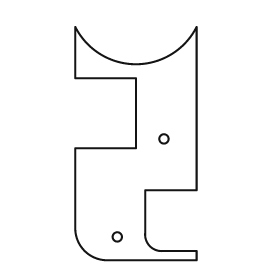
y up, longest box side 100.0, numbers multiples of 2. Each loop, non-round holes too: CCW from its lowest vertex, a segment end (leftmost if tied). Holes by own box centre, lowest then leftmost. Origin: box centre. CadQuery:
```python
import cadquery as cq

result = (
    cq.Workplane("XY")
    .moveTo(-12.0, -50.0)
    .lineTo(26.0, -50.0)
    .lineTo(26.0, -46.0)
    .lineTo(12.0, -46.0)
    .threePointArc((6.0, -44.0), (4.0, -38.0))
    .lineTo(4.0, -20.0)
    .lineTo(26.0, -20.0)
    .lineTo(26.0, 50.0)
    .threePointArc((0.0, 34.0), (-26.0, 50.0))
    .lineTo(-26.0, 28.0)
    .lineTo(0.0, 28.0)
    .lineTo(0.0, -2.0)
    .lineTo(-26.0, -2.0)
    .lineTo(-26.0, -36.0)
    .threePointArc((-22.0, -46.0), (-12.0, -50.0))
    .close()
    .moveTo(-8.0, -40.0)
    .circle(2.0)
    .moveTo(12.0, 2.0)
    .circle(2.0)
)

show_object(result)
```